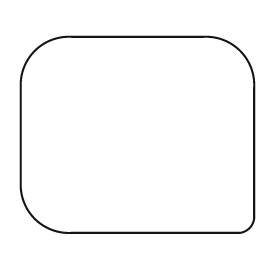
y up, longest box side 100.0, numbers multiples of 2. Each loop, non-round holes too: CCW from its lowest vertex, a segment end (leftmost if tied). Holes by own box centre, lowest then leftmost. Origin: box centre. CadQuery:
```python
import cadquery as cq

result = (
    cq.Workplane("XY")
    .moveTo(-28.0, -42.0)
    .lineTo(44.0, -42.0)
    .threePointArc((48.0, -40.0), (50.0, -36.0))
    .lineTo(50.0, 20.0)
    .threePointArc((44.0, 36.0), (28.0, 42.0))
    .lineTo(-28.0, 42.0)
    .threePointArc((-44.0, 36.0), (-50.0, 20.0))
    .lineTo(-50.0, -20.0)
    .threePointArc((-44.0, -36.0), (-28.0, -42.0))
    .close()
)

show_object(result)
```